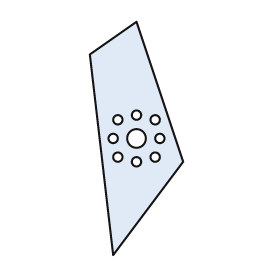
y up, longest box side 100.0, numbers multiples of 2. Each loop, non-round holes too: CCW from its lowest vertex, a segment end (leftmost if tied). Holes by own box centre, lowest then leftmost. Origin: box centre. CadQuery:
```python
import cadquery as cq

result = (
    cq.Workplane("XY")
    .moveTo(-10.0, -50.0)
    .lineTo(20.0, -10.0)
    .lineTo(0.0, 50.0)
    .lineTo(-20.0, 36.0)
    .close()
    .moveTo(0.0, -10.0)
    .circle(2.0)
    .moveTo(-8.0, -8.0)
    .circle(2.0)
    .moveTo(8.0, -8.0)
    .circle(2.0)
    .moveTo(-10.0, 0.0)
    .circle(2.0)
    .moveTo(0.0, 0.0)
    .circle(4.0)
    .moveTo(10.0, 0.0)
    .circle(2.0)
    .moveTo(-8.0, 8.0)
    .circle(2.0)
    .moveTo(8.0, 8.0)
    .circle(2.0)
    .moveTo(0.0, 10.0)
    .circle(2.0)
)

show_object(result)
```